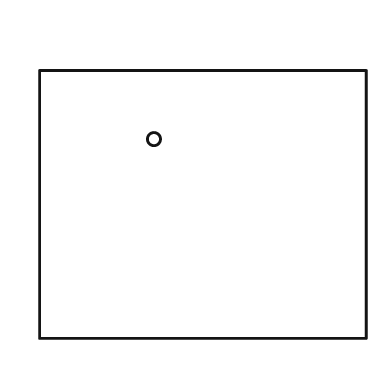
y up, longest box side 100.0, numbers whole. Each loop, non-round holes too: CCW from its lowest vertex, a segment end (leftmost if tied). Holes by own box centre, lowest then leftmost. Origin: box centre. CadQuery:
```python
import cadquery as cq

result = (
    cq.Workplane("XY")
    .moveTo(-50.0, -41.0)
    .lineTo(50.0, -41.0)
    .lineTo(50.0, 41.0)
    .lineTo(-50.0, 41.0)
    .close()
    .moveTo(-15.0, 20.0)
    .circle(2.0)
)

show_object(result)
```